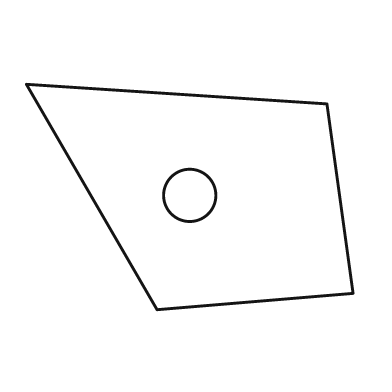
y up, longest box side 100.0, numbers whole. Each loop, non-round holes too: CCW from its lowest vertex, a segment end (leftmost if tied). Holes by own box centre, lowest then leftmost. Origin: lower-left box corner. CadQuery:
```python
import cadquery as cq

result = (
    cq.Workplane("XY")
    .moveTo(40.0, 0.0)
    .lineTo(100.0, 5.0)
    .lineTo(92.0, 63.0)
    .lineTo(0.0, 69.0)
    .close()
    .moveTo(50.0, 35.0)
    .circle(8.0)
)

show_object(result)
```